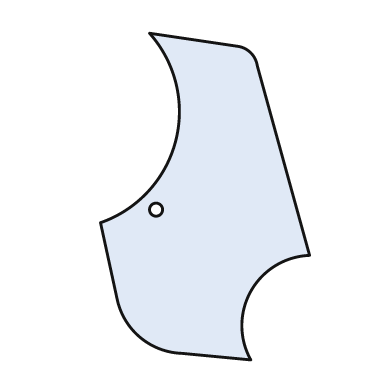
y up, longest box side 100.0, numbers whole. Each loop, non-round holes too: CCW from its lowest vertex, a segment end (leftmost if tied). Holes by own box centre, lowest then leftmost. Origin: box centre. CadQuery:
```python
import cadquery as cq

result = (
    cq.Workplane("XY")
    .moveTo(14.0, -50.0)
    .threePointArc((14.0, -29.0), (32.0, -18.0))
    .lineTo(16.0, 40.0)
    .threePointArc((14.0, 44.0), (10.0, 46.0))
    .lineTo(-17.0, 50.0)
    .threePointArc((-9.0, 17.0), (-32.0, -8.0))
    .lineTo(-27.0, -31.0)
    .threePointArc((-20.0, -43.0), (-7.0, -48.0))
    .close()
    .moveTo(-15.0, -4.0)
    .circle(2.0)
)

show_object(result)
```